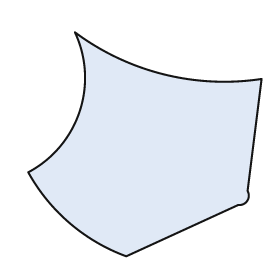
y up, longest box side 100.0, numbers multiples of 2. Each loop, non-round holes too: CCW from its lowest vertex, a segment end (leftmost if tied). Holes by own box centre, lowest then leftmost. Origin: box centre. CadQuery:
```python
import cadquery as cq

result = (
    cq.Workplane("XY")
    .moveTo(-8.0, -48.0)
    .lineTo(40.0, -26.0)
    .threePointArc((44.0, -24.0), (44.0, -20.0))
    .lineTo(50.0, 28.0)
    .threePointArc((8.0, 30.0), (-30.0, 48.0))
    .threePointArc((-28.0, 14.0), (-50.0, -12.0))
    .threePointArc((-32.0, -34.0), (-8.0, -48.0))
    .close()
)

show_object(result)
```